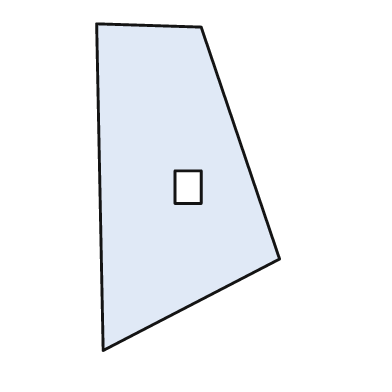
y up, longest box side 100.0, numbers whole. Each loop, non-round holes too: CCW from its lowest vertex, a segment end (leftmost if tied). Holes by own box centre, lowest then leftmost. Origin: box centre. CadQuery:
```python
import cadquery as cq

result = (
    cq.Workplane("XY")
    .moveTo(-26.0, -50.0)
    .lineTo(28.0, -22.0)
    .lineTo(4.0, 49.0)
    .lineTo(-28.0, 50.0)
    .close()
    .moveTo(-4.0, -5.0)
    .lineTo(4.0, -5.0)
    .lineTo(4.0, 5.0)
    .lineTo(-4.0, 5.0)
    .close()
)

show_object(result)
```